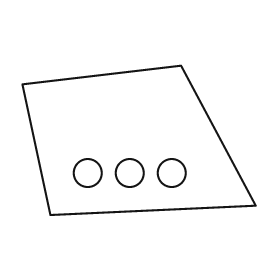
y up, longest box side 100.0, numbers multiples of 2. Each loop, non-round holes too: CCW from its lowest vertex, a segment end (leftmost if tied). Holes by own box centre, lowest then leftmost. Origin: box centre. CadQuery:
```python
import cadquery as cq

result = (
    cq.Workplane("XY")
    .moveTo(-38.0, -32.0)
    .lineTo(50.0, -28.0)
    .lineTo(18.0, 32.0)
    .lineTo(-50.0, 24.0)
    .close()
    .moveTo(-22.0, -14.0)
    .circle(6.0)
    .moveTo(-4.0, -14.0)
    .circle(6.0)
    .moveTo(14.0, -14.0)
    .circle(6.0)
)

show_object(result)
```